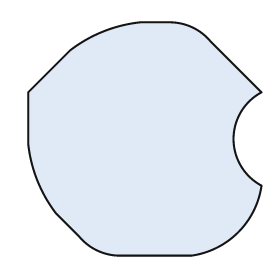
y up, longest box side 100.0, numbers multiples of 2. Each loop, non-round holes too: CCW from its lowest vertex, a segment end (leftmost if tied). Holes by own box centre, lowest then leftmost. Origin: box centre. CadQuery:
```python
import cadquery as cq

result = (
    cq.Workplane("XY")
    .moveTo(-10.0, -50.0)
    .lineTo(20.0, -50.0)
    .threePointArc((40.0, -40.0), (50.0, -20.0))
    .threePointArc((38.0, 0.0), (50.0, 20.0))
    .lineTo(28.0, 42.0)
    .threePointArc((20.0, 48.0), (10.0, 50.0))
    .lineTo(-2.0, 50.0)
    .threePointArc((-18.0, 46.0), (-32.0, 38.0))
    .lineTo(-50.0, 20.0)
    .lineTo(-50.0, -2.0)
    .threePointArc((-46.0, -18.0), (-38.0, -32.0))
    .lineTo(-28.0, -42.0)
    .threePointArc((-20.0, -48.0), (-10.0, -50.0))
    .close()
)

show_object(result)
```